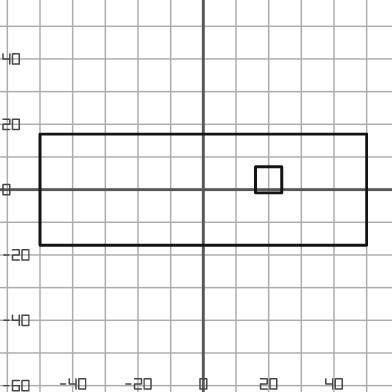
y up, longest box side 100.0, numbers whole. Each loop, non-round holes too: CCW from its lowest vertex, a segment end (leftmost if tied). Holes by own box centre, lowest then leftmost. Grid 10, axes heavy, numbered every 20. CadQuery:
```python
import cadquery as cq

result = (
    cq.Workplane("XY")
    .moveTo(-50.0, -17.0)
    .lineTo(50.0, -17.0)
    .lineTo(50.0, 17.0)
    .lineTo(-50.0, 17.0)
    .close()
    .moveTo(16.0, -1.0)
    .lineTo(24.0, -1.0)
    .lineTo(24.0, 7.0)
    .lineTo(16.0, 7.0)
    .close()
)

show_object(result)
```